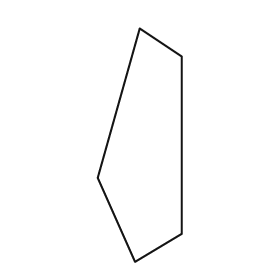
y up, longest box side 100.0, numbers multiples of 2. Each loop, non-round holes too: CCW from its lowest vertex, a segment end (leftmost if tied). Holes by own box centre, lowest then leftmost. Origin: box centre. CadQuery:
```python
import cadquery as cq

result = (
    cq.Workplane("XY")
    .moveTo(-2.0, -50.0)
    .lineTo(18.0, -38.0)
    .lineTo(18.0, 38.0)
    .lineTo(0.0, 50.0)
    .lineTo(-18.0, -14.0)
    .close()
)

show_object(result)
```